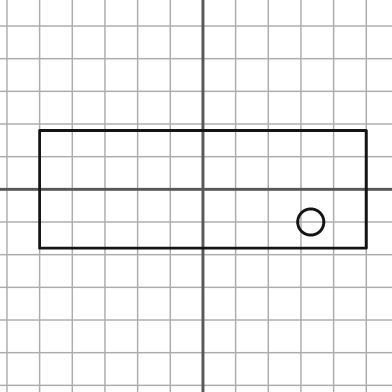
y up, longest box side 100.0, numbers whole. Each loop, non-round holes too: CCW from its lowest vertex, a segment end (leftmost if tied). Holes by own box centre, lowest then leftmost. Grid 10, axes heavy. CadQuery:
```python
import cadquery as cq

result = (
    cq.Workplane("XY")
    .moveTo(-50.0, -18.0)
    .lineTo(50.0, -18.0)
    .lineTo(50.0, 18.0)
    .lineTo(-50.0, 18.0)
    .close()
    .moveTo(33.0, -10.0)
    .circle(4.0)
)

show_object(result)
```